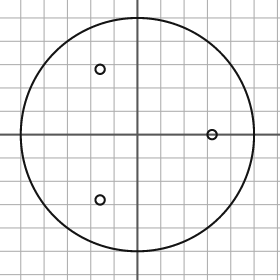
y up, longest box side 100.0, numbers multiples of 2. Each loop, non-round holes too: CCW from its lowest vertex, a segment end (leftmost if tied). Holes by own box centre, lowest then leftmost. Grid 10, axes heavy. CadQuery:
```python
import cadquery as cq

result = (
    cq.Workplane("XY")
    .moveTo(0.0, 0.0)
    .circle(50.0)
    .moveTo(-16.0, -28.0)
    .circle(2.0)
    .moveTo(32.0, 0.0)
    .circle(2.0)
    .moveTo(-16.0, 28.0)
    .circle(2.0)
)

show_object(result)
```